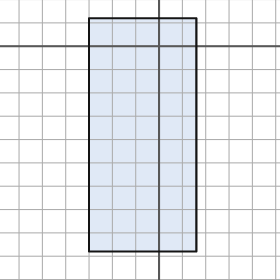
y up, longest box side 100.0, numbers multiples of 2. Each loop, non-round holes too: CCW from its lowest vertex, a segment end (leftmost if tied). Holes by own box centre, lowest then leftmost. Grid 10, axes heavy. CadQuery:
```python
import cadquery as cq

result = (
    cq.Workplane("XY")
    .moveTo(-30.0, -88.0)
    .lineTo(16.0, -88.0)
    .lineTo(16.0, 12.0)
    .lineTo(-30.0, 12.0)
    .close()
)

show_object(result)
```